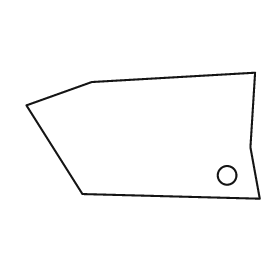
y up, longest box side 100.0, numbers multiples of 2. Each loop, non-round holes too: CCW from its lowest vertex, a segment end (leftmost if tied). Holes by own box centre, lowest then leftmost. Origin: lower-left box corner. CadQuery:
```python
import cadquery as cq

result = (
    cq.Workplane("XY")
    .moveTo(100.0, 0.0)
    .lineTo(96.0, 22.0)
    .lineTo(98.0, 54.0)
    .lineTo(28.0, 50.0)
    .lineTo(0.0, 40.0)
    .lineTo(24.0, 2.0)
    .close()
    .moveTo(86.0, 10.0)
    .circle(4.0)
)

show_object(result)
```